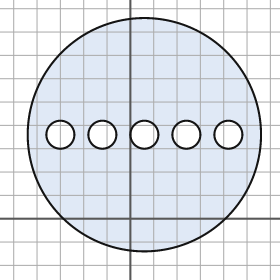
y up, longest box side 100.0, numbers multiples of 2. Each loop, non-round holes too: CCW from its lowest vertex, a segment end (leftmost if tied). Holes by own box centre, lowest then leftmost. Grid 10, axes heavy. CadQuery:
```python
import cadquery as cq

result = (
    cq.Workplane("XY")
    .moveTo(6.0, 36.0)
    .circle(50.0)
    .moveTo(-30.0, 36.0)
    .circle(6.0)
    .moveTo(-12.0, 36.0)
    .circle(6.0)
    .moveTo(6.0, 36.0)
    .circle(6.0)
    .moveTo(24.0, 36.0)
    .circle(6.0)
    .moveTo(42.0, 36.0)
    .circle(6.0)
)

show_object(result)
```